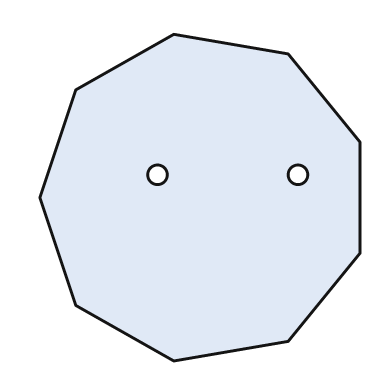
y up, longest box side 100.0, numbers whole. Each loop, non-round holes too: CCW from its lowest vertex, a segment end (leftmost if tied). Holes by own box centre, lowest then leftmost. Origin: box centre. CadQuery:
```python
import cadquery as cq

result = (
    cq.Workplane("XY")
    .moveTo(-8.0, -50.0)
    .lineTo(27.0, -44.0)
    .lineTo(49.0, -17.0)
    .lineTo(49.0, 17.0)
    .lineTo(27.0, 44.0)
    .lineTo(-8.0, 50.0)
    .lineTo(-38.0, 33.0)
    .lineTo(-49.0, 0.0)
    .lineTo(-38.0, -33.0)
    .close()
    .moveTo(-13.0, 7.0)
    .circle(3.0)
    .moveTo(30.0, 7.0)
    .circle(3.0)
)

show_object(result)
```